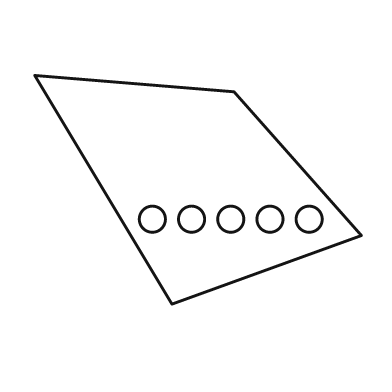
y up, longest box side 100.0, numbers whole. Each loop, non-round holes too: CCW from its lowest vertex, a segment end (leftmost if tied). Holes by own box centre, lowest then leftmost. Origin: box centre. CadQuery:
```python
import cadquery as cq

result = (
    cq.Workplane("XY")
    .moveTo(-8.0, -35.0)
    .lineTo(50.0, -14.0)
    .lineTo(11.0, 30.0)
    .lineTo(-50.0, 35.0)
    .close()
    .moveTo(-14.0, -9.0)
    .circle(4.0)
    .moveTo(-2.0, -9.0)
    .circle(4.0)
    .moveTo(10.0, -9.0)
    .circle(4.0)
    .moveTo(22.0, -9.0)
    .circle(4.0)
    .moveTo(34.0, -9.0)
    .circle(4.0)
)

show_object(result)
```